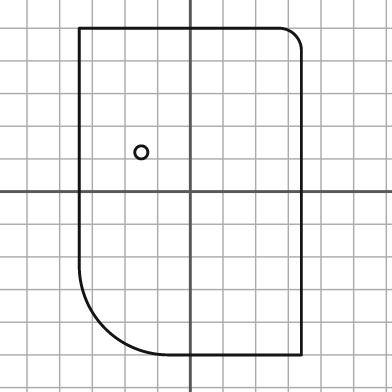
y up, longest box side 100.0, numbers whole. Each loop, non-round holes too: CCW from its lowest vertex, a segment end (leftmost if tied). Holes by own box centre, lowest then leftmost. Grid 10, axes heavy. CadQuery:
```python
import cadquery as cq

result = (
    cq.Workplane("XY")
    .moveTo(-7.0, -50.0)
    .lineTo(34.0, -50.0)
    .lineTo(34.0, 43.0)
    .threePointArc((32.0, 48.0), (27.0, 50.0))
    .lineTo(-34.0, 50.0)
    .lineTo(-34.0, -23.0)
    .threePointArc((-26.0, -42.0), (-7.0, -50.0))
    .close()
    .moveTo(-15.0, 12.0)
    .circle(2.0)
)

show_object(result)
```